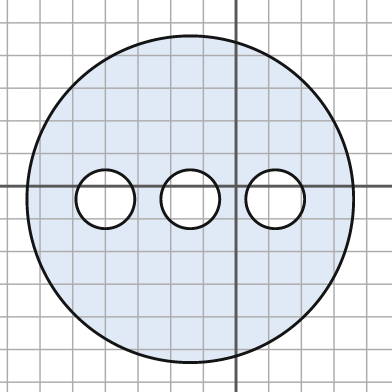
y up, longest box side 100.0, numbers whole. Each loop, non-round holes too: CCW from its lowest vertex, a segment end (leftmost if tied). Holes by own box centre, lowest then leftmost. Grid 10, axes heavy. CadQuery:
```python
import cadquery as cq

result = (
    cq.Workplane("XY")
    .moveTo(-14.0, -4.0)
    .circle(50.0)
    .moveTo(-40.0, -4.0)
    .circle(9.0)
    .moveTo(-14.0, -4.0)
    .circle(9.0)
    .moveTo(12.0, -4.0)
    .circle(9.0)
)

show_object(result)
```